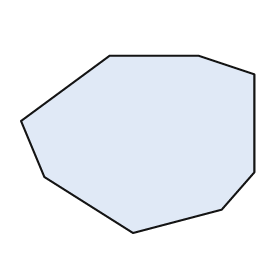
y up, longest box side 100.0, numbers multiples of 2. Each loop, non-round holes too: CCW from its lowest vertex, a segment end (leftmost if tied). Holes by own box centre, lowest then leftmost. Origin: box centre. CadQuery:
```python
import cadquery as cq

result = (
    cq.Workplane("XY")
    .moveTo(-2.0, -38.0)
    .lineTo(36.0, -28.0)
    .lineTo(50.0, -12.0)
    .lineTo(50.0, 30.0)
    .lineTo(26.0, 38.0)
    .lineTo(-12.0, 38.0)
    .lineTo(-50.0, 10.0)
    .lineTo(-40.0, -14.0)
    .close()
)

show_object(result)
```